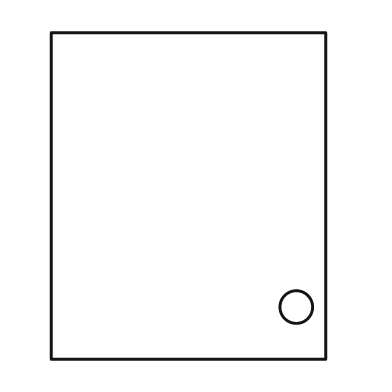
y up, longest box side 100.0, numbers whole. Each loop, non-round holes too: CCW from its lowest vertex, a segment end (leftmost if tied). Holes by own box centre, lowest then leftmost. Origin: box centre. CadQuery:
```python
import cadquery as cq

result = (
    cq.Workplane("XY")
    .moveTo(-42.0, -50.0)
    .lineTo(42.0, -50.0)
    .lineTo(42.0, 50.0)
    .lineTo(-42.0, 50.0)
    .close()
    .moveTo(33.0, -34.0)
    .circle(5.0)
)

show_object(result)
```